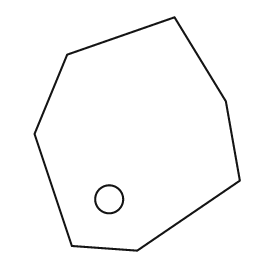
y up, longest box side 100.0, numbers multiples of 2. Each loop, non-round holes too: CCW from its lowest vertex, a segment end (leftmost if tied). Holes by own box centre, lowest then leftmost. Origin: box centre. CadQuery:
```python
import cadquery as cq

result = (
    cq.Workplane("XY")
    .moveTo(0.0, -50.0)
    .lineTo(44.0, -20.0)
    .lineTo(38.0, 14.0)
    .lineTo(16.0, 50.0)
    .lineTo(-30.0, 34.0)
    .lineTo(-44.0, 0.0)
    .lineTo(-28.0, -48.0)
    .close()
    .moveTo(-12.0, -28.0)
    .circle(6.0)
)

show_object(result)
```